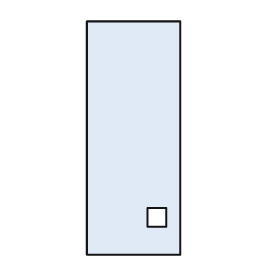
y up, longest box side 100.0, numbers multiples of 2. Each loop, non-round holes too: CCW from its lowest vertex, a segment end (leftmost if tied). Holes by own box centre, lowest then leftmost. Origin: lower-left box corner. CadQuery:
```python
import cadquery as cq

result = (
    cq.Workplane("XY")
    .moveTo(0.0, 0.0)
    .lineTo(40.0, 0.0)
    .lineTo(40.0, 100.0)
    .lineTo(0.0, 100.0)
    .close()
    .moveTo(26.0, 12.0)
    .lineTo(34.0, 12.0)
    .lineTo(34.0, 20.0)
    .lineTo(26.0, 20.0)
    .close()
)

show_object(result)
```